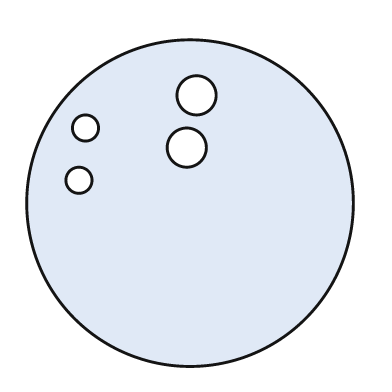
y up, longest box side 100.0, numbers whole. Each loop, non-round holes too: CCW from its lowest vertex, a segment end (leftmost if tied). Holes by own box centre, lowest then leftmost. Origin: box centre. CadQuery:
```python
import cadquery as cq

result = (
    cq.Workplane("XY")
    .moveTo(0.0, 0.0)
    .circle(50.0)
    .moveTo(-34.0, 7.0)
    .circle(4.0)
    .moveTo(-1.0, 17.0)
    .circle(6.0)
    .moveTo(-32.0, 23.0)
    .circle(4.0)
    .moveTo(2.0, 33.0)
    .circle(6.0)
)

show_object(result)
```